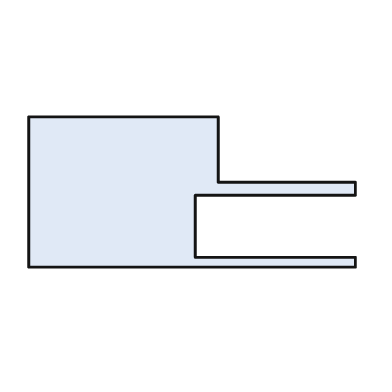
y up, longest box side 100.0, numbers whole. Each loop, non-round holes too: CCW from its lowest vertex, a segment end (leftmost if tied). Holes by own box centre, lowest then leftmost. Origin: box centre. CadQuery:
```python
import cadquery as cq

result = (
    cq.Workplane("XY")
    .moveTo(-50.0, -23.0)
    .lineTo(50.0, -23.0)
    .lineTo(50.0, -20.0)
    .lineTo(1.0, -20.0)
    .lineTo(1.0, -1.0)
    .lineTo(50.0, -1.0)
    .lineTo(50.0, 3.0)
    .lineTo(8.0, 3.0)
    .lineTo(8.0, 23.0)
    .lineTo(-50.0, 23.0)
    .close()
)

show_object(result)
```